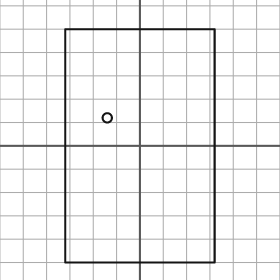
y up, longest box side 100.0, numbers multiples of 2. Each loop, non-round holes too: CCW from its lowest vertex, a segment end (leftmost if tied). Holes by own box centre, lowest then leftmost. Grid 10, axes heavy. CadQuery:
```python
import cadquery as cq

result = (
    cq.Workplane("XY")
    .moveTo(-32.0, -50.0)
    .lineTo(32.0, -50.0)
    .lineTo(32.0, 50.0)
    .lineTo(-32.0, 50.0)
    .close()
    .moveTo(-14.0, 12.0)
    .circle(2.0)
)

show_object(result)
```